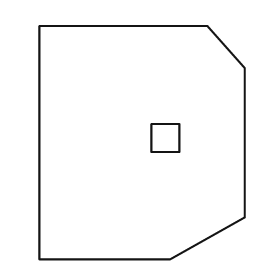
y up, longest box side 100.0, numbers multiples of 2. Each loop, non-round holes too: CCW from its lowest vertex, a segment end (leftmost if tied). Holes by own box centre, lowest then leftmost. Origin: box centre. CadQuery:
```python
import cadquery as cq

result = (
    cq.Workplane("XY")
    .moveTo(-44.0, -50.0)
    .lineTo(12.0, -50.0)
    .lineTo(44.0, -32.0)
    .lineTo(44.0, 32.0)
    .lineTo(28.0, 50.0)
    .lineTo(-44.0, 50.0)
    .close()
    .moveTo(4.0, -4.0)
    .lineTo(16.0, -4.0)
    .lineTo(16.0, 8.0)
    .lineTo(4.0, 8.0)
    .close()
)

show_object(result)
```